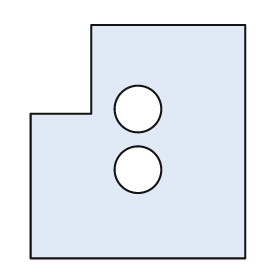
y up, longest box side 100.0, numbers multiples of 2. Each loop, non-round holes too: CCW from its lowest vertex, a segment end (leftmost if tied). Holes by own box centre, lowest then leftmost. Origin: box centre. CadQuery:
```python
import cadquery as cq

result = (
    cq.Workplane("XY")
    .moveTo(-46.0, -50.0)
    .lineTo(46.0, -50.0)
    .lineTo(46.0, 50.0)
    .lineTo(-20.0, 50.0)
    .lineTo(-20.0, 12.0)
    .lineTo(-46.0, 12.0)
    .close()
    .moveTo(0.0, -12.0)
    .circle(10.0)
    .moveTo(0.0, 14.0)
    .circle(10.0)
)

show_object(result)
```